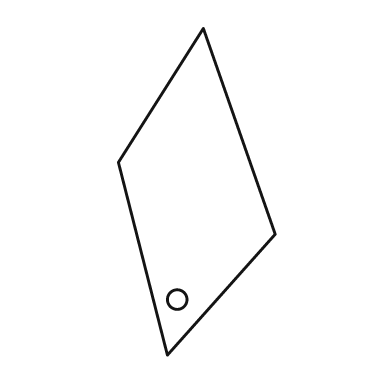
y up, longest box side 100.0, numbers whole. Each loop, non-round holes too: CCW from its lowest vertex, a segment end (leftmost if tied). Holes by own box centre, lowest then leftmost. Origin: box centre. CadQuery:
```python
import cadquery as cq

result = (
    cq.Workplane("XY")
    .moveTo(-9.0, -50.0)
    .lineTo(24.0, -13.0)
    .lineTo(2.0, 50.0)
    .lineTo(-24.0, 9.0)
    .close()
    .moveTo(-6.0, -33.0)
    .circle(3.0)
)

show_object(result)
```